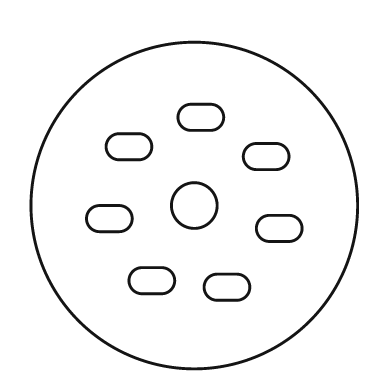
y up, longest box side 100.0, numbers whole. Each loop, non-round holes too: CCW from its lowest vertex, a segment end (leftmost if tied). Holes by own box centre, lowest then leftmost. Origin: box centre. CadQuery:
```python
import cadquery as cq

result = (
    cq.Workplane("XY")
    .moveTo(0.0, 0.0)
    .circle(50.0)
    .moveTo(7.0, -29.0)
    .lineTo(13.0, -29.0)
    .threePointArc((17.0, -25.0), (13.0, -21.0))
    .lineTo(7.0, -21.0)
    .threePointArc((3.0, -25.0), (7.0, -29.0))
    .close()
    .moveTo(-16.0, -27.0)
    .lineTo(-10.0, -27.0)
    .threePointArc((-6.0, -23.0), (-10.0, -19.0))
    .lineTo(-16.0, -19.0)
    .threePointArc((-20.0, -23.0), (-16.0, -27.0))
    .close()
    .moveTo(23.0, -11.0)
    .lineTo(29.0, -11.0)
    .threePointArc((33.0, -7.0), (29.0, -3.0))
    .lineTo(23.0, -3.0)
    .threePointArc((19.0, -7.0), (23.0, -11.0))
    .close()
    .moveTo(-29.0, -8.0)
    .lineTo(-23.0, -8.0)
    .threePointArc((-19.0, -4.0), (-23.0, 0.0))
    .lineTo(-29.0, 0.0)
    .threePointArc((-33.0, -4.0), (-29.0, -8.0))
    .close()
    .moveTo(0.0, 0.0)
    .circle(7.0)
    .moveTo(19.0, 11.0)
    .lineTo(25.0, 11.0)
    .threePointArc((29.0, 15.0), (25.0, 19.0))
    .lineTo(19.0, 19.0)
    .threePointArc((15.0, 15.0), (19.0, 11.0))
    .close()
    .moveTo(-23.0, 14.0)
    .lineTo(-17.0, 14.0)
    .threePointArc((-13.0, 18.0), (-17.0, 22.0))
    .lineTo(-23.0, 22.0)
    .threePointArc((-27.0, 18.0), (-23.0, 14.0))
    .close()
    .moveTo(-1.0, 23.0)
    .lineTo(5.0, 23.0)
    .threePointArc((9.0, 27.0), (5.0, 31.0))
    .lineTo(-1.0, 31.0)
    .threePointArc((-5.0, 27.0), (-1.0, 23.0))
    .close()
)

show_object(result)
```